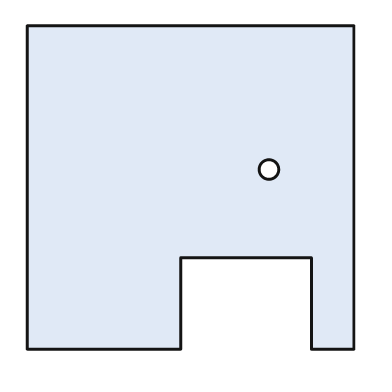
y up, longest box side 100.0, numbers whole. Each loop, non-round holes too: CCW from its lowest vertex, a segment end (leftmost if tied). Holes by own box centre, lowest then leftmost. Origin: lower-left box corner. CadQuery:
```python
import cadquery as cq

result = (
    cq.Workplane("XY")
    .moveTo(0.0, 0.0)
    .lineTo(47.0, 0.0)
    .lineTo(47.0, 28.0)
    .lineTo(87.0, 28.0)
    .lineTo(87.0, 0.0)
    .lineTo(100.0, 0.0)
    .lineTo(100.0, 99.0)
    .lineTo(0.0, 99.0)
    .close()
    .moveTo(74.0, 55.0)
    .circle(3.0)
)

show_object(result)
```